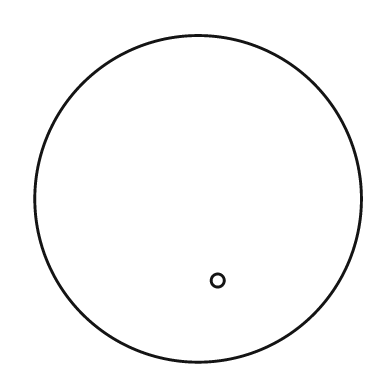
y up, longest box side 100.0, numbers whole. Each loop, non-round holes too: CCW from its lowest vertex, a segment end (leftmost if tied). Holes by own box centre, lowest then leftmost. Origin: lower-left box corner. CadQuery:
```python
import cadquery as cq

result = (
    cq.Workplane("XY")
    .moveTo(50.0, 50.0)
    .circle(50.0)
    .moveTo(56.0, 25.0)
    .circle(2.0)
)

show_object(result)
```